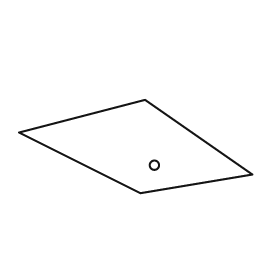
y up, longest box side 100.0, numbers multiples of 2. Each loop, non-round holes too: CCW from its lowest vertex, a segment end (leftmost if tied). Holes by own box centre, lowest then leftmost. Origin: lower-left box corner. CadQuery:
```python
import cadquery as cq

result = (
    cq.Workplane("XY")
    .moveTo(52.0, 0.0)
    .lineTo(100.0, 8.0)
    .lineTo(54.0, 40.0)
    .lineTo(0.0, 26.0)
    .close()
    .moveTo(58.0, 12.0)
    .circle(2.0)
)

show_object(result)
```